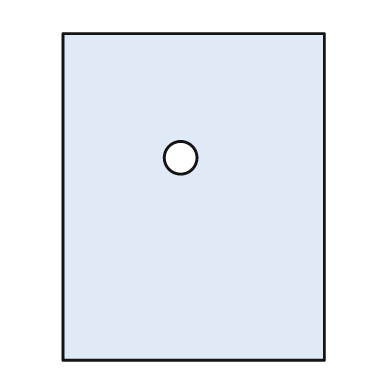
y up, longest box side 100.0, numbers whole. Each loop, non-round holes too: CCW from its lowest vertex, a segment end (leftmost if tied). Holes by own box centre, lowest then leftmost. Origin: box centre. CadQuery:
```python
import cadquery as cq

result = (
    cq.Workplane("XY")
    .moveTo(-40.0, -50.0)
    .lineTo(40.0, -50.0)
    .lineTo(40.0, 50.0)
    .lineTo(-40.0, 50.0)
    .close()
    .moveTo(-4.0, 12.0)
    .circle(5.0)
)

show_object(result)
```